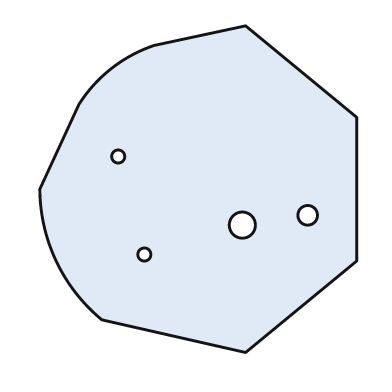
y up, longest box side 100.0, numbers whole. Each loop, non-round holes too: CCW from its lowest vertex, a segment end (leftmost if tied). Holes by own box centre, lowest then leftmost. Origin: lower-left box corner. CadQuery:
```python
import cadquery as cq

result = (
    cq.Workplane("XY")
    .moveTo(63.0, 0.0)
    .lineTo(97.0, 28.0)
    .lineTo(97.0, 72.0)
    .lineTo(63.0, 100.0)
    .lineTo(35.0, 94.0)
    .threePointArc((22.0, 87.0), (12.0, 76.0))
    .lineTo(0.0, 50.0)
    .threePointArc((5.0, 28.0), (19.0, 10.0))
    .close()
    .moveTo(32.0, 30.0)
    .circle(2.0)
    .moveTo(62.0, 39.0)
    .circle(4.0)
    .moveTo(82.0, 42.0)
    .circle(3.0)
    .moveTo(24.0, 60.0)
    .circle(2.0)
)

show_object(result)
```